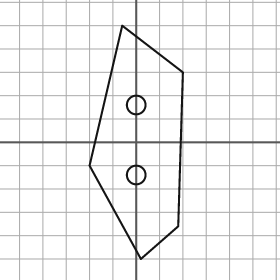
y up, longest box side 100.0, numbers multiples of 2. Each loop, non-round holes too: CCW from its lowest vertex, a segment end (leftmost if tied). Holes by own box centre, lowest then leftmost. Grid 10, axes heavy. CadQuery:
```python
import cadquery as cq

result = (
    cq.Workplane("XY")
    .moveTo(2.0, -50.0)
    .lineTo(18.0, -36.0)
    .lineTo(20.0, 30.0)
    .lineTo(-6.0, 50.0)
    .lineTo(-20.0, -10.0)
    .close()
    .moveTo(0.0, -14.0)
    .circle(4.0)
    .moveTo(0.0, 16.0)
    .circle(4.0)
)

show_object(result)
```